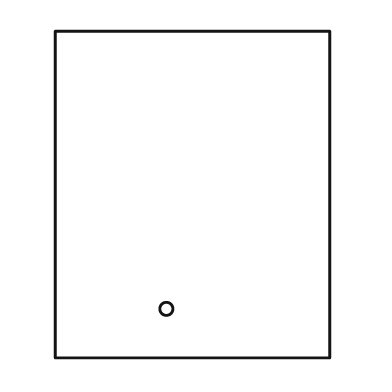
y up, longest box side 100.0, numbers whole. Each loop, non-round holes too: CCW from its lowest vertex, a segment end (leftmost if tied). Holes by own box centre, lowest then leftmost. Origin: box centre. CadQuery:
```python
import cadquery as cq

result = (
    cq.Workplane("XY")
    .moveTo(-42.0, -50.0)
    .lineTo(42.0, -50.0)
    .lineTo(42.0, 50.0)
    .lineTo(-42.0, 50.0)
    .close()
    .moveTo(-8.0, -35.0)
    .circle(2.0)
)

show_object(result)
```